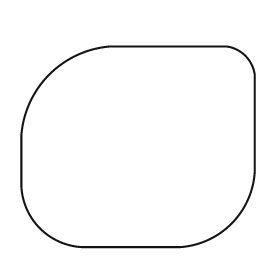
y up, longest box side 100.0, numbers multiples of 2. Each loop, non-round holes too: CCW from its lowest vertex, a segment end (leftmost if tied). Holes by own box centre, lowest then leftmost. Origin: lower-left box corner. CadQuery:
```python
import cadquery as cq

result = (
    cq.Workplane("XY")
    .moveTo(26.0, 0.0)
    .lineTo(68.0, 0.0)
    .threePointArc((90.0, 10.0), (100.0, 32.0))
    .lineTo(100.0, 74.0)
    .threePointArc((96.0, 82.0), (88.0, 86.0))
    .lineTo(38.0, 86.0)
    .threePointArc((12.0, 74.0), (0.0, 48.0))
    .lineTo(0.0, 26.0)
    .threePointArc((8.0, 8.0), (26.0, 0.0))
    .close()
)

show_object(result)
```